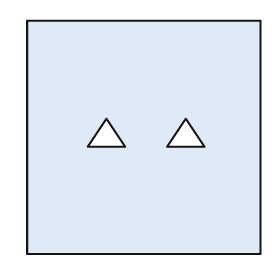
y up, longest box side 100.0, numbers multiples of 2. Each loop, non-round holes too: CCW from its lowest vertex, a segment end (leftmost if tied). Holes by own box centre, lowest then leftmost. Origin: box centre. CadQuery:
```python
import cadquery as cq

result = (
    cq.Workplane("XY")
    .moveTo(-50.0, -50.0)
    .lineTo(50.0, -50.0)
    .lineTo(50.0, 50.0)
    .lineTo(-50.0, 50.0)
    .close()
    .moveTo(-24.0, -4.0)
    .lineTo(-8.0, -4.0)
    .lineTo(-16.0, 8.0)
    .close()
    .moveTo(10.0, -4.0)
    .lineTo(26.0, -4.0)
    .lineTo(18.0, 8.0)
    .close()
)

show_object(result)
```